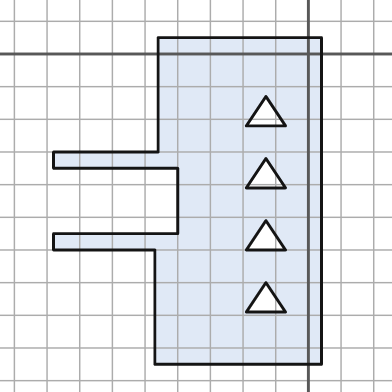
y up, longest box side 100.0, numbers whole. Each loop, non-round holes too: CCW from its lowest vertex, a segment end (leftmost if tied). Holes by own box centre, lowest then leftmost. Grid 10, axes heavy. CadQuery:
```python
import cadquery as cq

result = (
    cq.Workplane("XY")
    .moveTo(-47.0, -95.0)
    .lineTo(4.0, -95.0)
    .lineTo(4.0, 5.0)
    .lineTo(-46.0, 5.0)
    .lineTo(-46.0, -30.0)
    .lineTo(-78.0, -30.0)
    .lineTo(-78.0, -35.0)
    .lineTo(-40.0, -35.0)
    .lineTo(-40.0, -55.0)
    .lineTo(-78.0, -55.0)
    .lineTo(-78.0, -60.0)
    .lineTo(-47.0, -60.0)
    .close()
    .moveTo(-19.0, -79.0)
    .lineTo(-7.0, -79.0)
    .lineTo(-13.0, -70.0)
    .close()
    .moveTo(-19.0, -60.0)
    .lineTo(-7.0, -60.0)
    .lineTo(-13.0, -51.0)
    .close()
    .moveTo(-19.0, -41.0)
    .lineTo(-7.0, -41.0)
    .lineTo(-13.0, -32.0)
    .close()
    .moveTo(-19.0, -22.0)
    .lineTo(-7.0, -22.0)
    .lineTo(-13.0, -13.0)
    .close()
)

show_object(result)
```